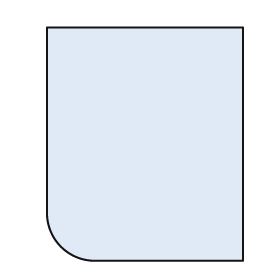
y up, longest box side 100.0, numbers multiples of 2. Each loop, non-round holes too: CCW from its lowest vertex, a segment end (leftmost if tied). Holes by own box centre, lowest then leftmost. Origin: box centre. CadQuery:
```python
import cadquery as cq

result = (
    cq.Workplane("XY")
    .moveTo(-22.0, -50.0)
    .lineTo(42.0, -50.0)
    .lineTo(42.0, 50.0)
    .lineTo(-42.0, 50.0)
    .lineTo(-42.0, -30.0)
    .threePointArc((-36.0, -44.0), (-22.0, -50.0))
    .close()
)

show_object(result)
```